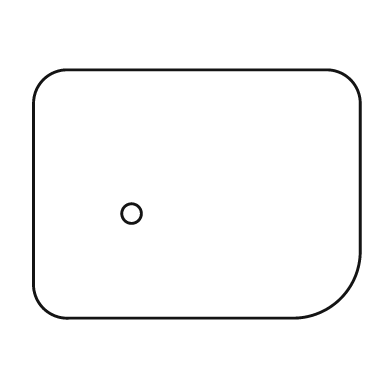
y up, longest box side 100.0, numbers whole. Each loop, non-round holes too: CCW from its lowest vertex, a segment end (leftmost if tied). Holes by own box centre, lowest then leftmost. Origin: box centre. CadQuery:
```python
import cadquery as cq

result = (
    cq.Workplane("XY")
    .moveTo(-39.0, -38.0)
    .lineTo(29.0, -38.0)
    .threePointArc((44.0, -32.0), (50.0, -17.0))
    .lineTo(50.0, 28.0)
    .threePointArc((47.0, 35.0), (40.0, 38.0))
    .lineTo(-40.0, 38.0)
    .threePointArc((-47.0, 35.0), (-50.0, 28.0))
    .lineTo(-50.0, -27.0)
    .threePointArc((-47.0, -35.0), (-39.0, -38.0))
    .close()
    .moveTo(-20.0, -6.0)
    .circle(3.0)
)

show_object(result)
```